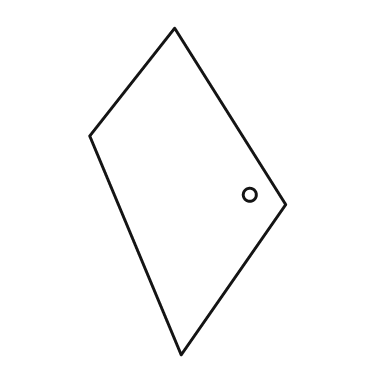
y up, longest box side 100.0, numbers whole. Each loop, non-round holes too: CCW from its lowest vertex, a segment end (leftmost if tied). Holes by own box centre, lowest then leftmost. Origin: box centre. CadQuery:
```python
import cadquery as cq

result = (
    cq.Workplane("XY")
    .moveTo(-2.0, -50.0)
    .lineTo(30.0, -4.0)
    .lineTo(-4.0, 50.0)
    .lineTo(-30.0, 17.0)
    .close()
    .moveTo(19.0, -1.0)
    .circle(2.0)
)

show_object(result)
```